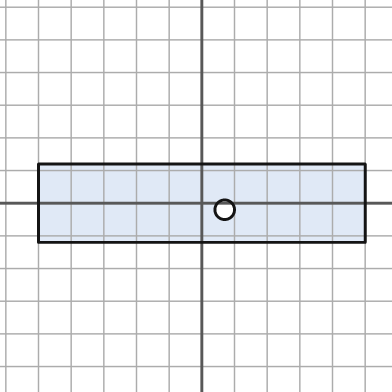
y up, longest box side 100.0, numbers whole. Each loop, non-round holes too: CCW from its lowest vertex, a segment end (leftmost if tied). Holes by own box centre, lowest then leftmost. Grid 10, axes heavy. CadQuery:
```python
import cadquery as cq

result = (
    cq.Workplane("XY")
    .moveTo(-50.0, -12.0)
    .lineTo(50.0, -12.0)
    .lineTo(50.0, 12.0)
    .lineTo(-50.0, 12.0)
    .close()
    .moveTo(7.0, -2.0)
    .circle(3.0)
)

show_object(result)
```